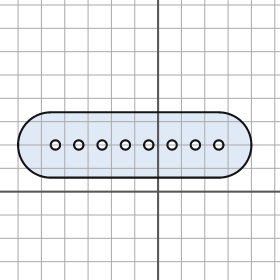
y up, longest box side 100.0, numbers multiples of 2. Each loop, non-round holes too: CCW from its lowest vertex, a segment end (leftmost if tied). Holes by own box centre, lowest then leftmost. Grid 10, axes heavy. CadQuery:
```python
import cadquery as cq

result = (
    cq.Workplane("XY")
    .moveTo(-46.0, 6.0)
    .lineTo(26.0, 6.0)
    .threePointArc((40.0, 20.0), (26.0, 34.0))
    .lineTo(-46.0, 34.0)
    .threePointArc((-60.0, 20.0), (-46.0, 6.0))
    .close()
    .moveTo(-44.0, 20.0)
    .circle(2.0)
    .moveTo(-34.0, 20.0)
    .circle(2.0)
    .moveTo(-24.0, 20.0)
    .circle(2.0)
    .moveTo(-14.0, 20.0)
    .circle(2.0)
    .moveTo(-4.0, 20.0)
    .circle(2.0)
    .moveTo(6.0, 20.0)
    .circle(2.0)
    .moveTo(16.0, 20.0)
    .circle(2.0)
    .moveTo(26.0, 20.0)
    .circle(2.0)
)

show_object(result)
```